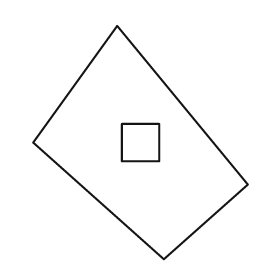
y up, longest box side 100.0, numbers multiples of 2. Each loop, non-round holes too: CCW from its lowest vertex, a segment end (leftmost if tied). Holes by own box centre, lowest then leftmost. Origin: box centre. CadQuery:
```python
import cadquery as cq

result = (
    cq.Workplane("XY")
    .moveTo(10.0, -50.0)
    .lineTo(46.0, -18.0)
    .lineTo(-10.0, 50.0)
    .lineTo(-46.0, 0.0)
    .close()
    .moveTo(-8.0, -8.0)
    .lineTo(8.0, -8.0)
    .lineTo(8.0, 8.0)
    .lineTo(-8.0, 8.0)
    .close()
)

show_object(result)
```